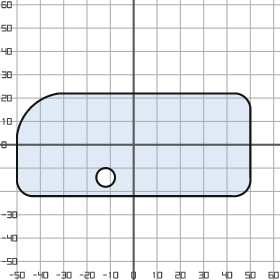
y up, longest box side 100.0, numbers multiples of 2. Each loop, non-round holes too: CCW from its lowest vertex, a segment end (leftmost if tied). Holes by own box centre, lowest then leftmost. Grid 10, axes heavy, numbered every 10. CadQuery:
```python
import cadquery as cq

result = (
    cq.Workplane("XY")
    .moveTo(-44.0, -22.0)
    .lineTo(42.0, -22.0)
    .threePointArc((48.0, -20.0), (50.0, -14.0))
    .lineTo(50.0, 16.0)
    .threePointArc((48.0, 20.0), (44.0, 22.0))
    .lineTo(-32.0, 22.0)
    .threePointArc((-44.0, 16.0), (-50.0, 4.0))
    .lineTo(-50.0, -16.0)
    .threePointArc((-48.0, -20.0), (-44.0, -22.0))
    .close()
    .moveTo(-12.0, -14.0)
    .circle(4.0)
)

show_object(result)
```